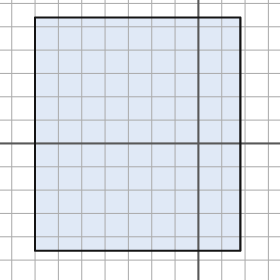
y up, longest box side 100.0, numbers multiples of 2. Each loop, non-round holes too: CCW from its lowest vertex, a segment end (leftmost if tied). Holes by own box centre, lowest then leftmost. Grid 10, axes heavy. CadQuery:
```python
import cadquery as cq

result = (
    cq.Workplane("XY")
    .moveTo(-70.0, -46.0)
    .lineTo(18.0, -46.0)
    .lineTo(18.0, 54.0)
    .lineTo(-70.0, 54.0)
    .close()
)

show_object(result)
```